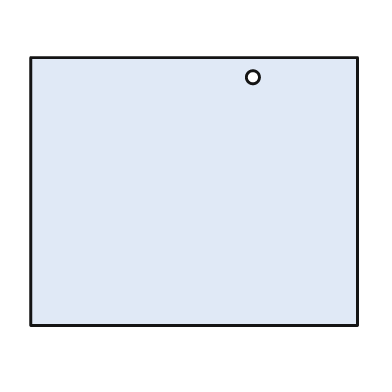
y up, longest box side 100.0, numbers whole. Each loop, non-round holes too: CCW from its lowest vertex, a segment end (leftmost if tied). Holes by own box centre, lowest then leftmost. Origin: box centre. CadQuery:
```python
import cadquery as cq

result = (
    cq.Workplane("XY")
    .moveTo(-50.0, -41.0)
    .lineTo(50.0, -41.0)
    .lineTo(50.0, 41.0)
    .lineTo(-50.0, 41.0)
    .close()
    .moveTo(18.0, 35.0)
    .circle(2.0)
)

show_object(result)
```